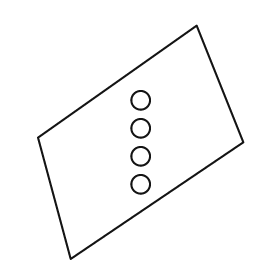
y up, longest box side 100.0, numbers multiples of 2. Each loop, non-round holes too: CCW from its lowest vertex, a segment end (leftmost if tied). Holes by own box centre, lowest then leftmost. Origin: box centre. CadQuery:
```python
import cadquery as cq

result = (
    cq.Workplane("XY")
    .moveTo(-30.0, -50.0)
    .lineTo(44.0, 0.0)
    .lineTo(24.0, 50.0)
    .lineTo(-44.0, 2.0)
    .close()
    .moveTo(0.0, -18.0)
    .circle(4.0)
    .moveTo(0.0, -6.0)
    .circle(4.0)
    .moveTo(0.0, 6.0)
    .circle(4.0)
    .moveTo(0.0, 18.0)
    .circle(4.0)
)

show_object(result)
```